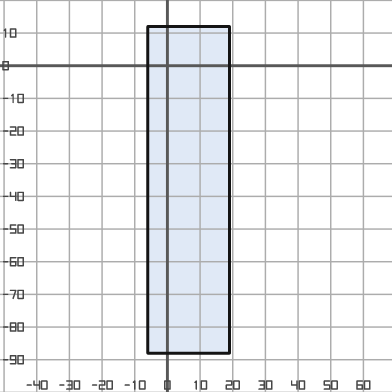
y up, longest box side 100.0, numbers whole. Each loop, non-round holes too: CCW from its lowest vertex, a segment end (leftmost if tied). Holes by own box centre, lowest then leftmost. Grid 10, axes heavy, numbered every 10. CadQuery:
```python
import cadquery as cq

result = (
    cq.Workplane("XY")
    .moveTo(-6.0, -88.0)
    .lineTo(19.0, -88.0)
    .lineTo(19.0, 12.0)
    .lineTo(-6.0, 12.0)
    .close()
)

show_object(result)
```